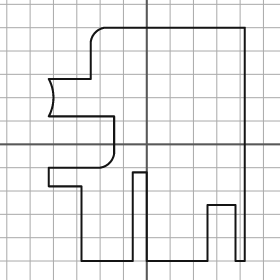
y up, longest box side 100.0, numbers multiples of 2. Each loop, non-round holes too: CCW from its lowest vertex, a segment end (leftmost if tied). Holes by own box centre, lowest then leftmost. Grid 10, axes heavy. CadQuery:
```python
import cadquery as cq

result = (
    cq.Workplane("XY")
    .moveTo(-28.0, -50.0)
    .lineTo(-6.0, -50.0)
    .lineTo(-6.0, -12.0)
    .lineTo(0.0, -12.0)
    .lineTo(0.0, -50.0)
    .lineTo(26.0, -50.0)
    .lineTo(26.0, -26.0)
    .lineTo(38.0, -26.0)
    .lineTo(38.0, -50.0)
    .lineTo(42.0, -50.0)
    .lineTo(42.0, 50.0)
    .lineTo(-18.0, 50.0)
    .threePointArc((-22.0, 48.0), (-24.0, 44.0))
    .lineTo(-24.0, 28.0)
    .lineTo(-42.0, 28.0)
    .threePointArc((-40.0, 20.0), (-42.0, 12.0))
    .lineTo(-14.0, 12.0)
    .lineTo(-14.0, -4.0)
    .threePointArc((-16.0, -8.0), (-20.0, -10.0))
    .lineTo(-42.0, -10.0)
    .lineTo(-42.0, -18.0)
    .lineTo(-28.0, -18.0)
    .close()
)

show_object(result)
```